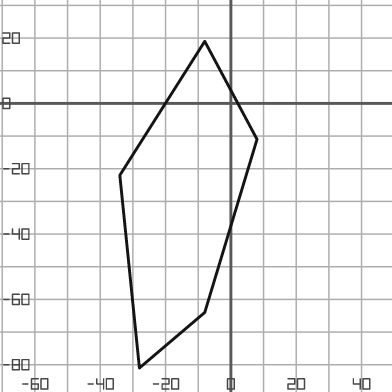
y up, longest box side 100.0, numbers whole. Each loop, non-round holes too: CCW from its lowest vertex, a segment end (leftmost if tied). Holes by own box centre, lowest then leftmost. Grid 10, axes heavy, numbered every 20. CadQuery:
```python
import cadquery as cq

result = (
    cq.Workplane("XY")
    .moveTo(-28.0, -81.0)
    .lineTo(-8.0, -64.0)
    .lineTo(8.0, -11.0)
    .lineTo(-8.0, 19.0)
    .lineTo(-34.0, -22.0)
    .close()
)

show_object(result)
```